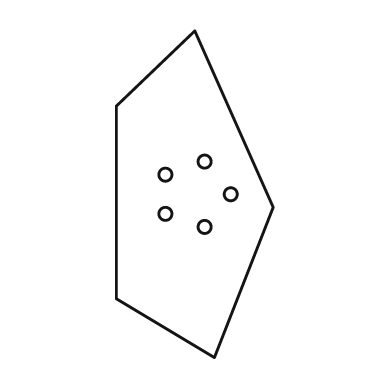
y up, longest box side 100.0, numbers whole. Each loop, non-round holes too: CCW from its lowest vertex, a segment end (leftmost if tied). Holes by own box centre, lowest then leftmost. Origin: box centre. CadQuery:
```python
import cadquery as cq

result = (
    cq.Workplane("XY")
    .moveTo(6.0, -50.0)
    .lineTo(24.0, -4.0)
    .lineTo(0.0, 50.0)
    .lineTo(-24.0, 27.0)
    .lineTo(-24.0, -32.0)
    .close()
    .moveTo(3.0, -10.0)
    .circle(2.0)
    .moveTo(-9.0, -6.0)
    .circle(2.0)
    .moveTo(11.0, 0.0)
    .circle(2.0)
    .moveTo(-9.0, 6.0)
    .circle(2.0)
    .moveTo(3.0, 10.0)
    .circle(2.0)
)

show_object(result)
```